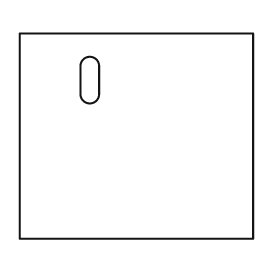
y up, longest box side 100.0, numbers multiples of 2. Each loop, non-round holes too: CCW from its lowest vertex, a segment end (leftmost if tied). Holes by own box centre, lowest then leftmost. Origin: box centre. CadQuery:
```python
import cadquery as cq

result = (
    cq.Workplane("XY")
    .moveTo(-50.0, -44.0)
    .lineTo(50.0, -44.0)
    .lineTo(50.0, 44.0)
    .lineTo(-50.0, 44.0)
    .close()
    .moveTo(-24.0, 18.0)
    .threePointArc((-20.0, 14.0), (-16.0, 18.0))
    .lineTo(-16.0, 30.0)
    .threePointArc((-20.0, 34.0), (-24.0, 30.0))
    .close()
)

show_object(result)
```